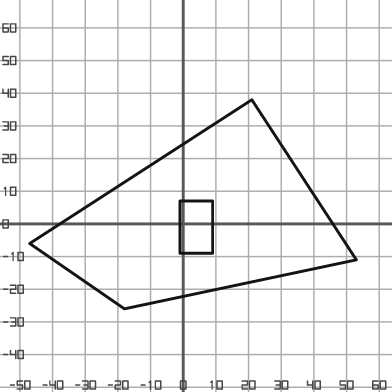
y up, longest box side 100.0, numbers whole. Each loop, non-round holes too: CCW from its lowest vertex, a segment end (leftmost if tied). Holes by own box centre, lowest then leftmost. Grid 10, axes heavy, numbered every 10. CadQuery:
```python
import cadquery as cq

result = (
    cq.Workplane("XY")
    .moveTo(-18.0, -26.0)
    .lineTo(53.0, -11.0)
    .lineTo(21.0, 38.0)
    .lineTo(-47.0, -6.0)
    .close()
    .moveTo(-1.0, -9.0)
    .lineTo(9.0, -9.0)
    .lineTo(9.0, 7.0)
    .lineTo(-1.0, 7.0)
    .close()
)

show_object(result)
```